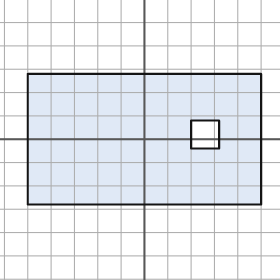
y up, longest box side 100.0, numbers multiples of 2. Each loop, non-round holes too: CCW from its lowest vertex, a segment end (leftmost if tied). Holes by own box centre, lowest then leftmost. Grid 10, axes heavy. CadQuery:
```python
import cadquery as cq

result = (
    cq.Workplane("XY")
    .moveTo(-50.0, -28.0)
    .lineTo(50.0, -28.0)
    .lineTo(50.0, 28.0)
    .lineTo(-50.0, 28.0)
    .close()
    .moveTo(20.0, -4.0)
    .lineTo(32.0, -4.0)
    .lineTo(32.0, 8.0)
    .lineTo(20.0, 8.0)
    .close()
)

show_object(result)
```